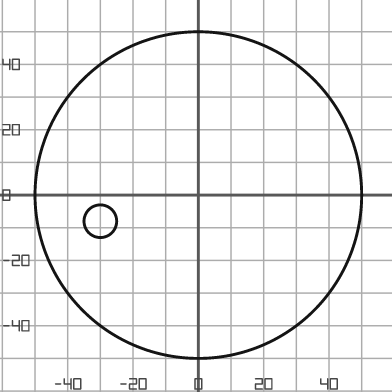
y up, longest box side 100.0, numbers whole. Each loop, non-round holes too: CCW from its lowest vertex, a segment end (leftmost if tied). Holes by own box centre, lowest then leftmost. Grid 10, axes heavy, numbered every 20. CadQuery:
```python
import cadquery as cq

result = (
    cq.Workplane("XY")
    .moveTo(0.0, 0.0)
    .circle(50.0)
    .moveTo(-30.0, -8.0)
    .circle(5.0)
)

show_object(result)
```